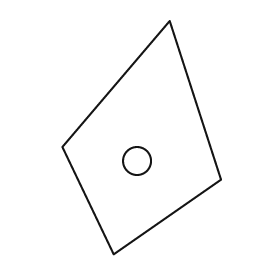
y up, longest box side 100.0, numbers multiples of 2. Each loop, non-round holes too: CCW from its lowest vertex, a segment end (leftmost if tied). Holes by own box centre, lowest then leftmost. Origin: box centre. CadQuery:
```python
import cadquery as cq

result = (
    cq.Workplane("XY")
    .moveTo(-12.0, -50.0)
    .lineTo(34.0, -18.0)
    .lineTo(12.0, 50.0)
    .lineTo(-34.0, -4.0)
    .close()
    .moveTo(-2.0, -10.0)
    .circle(6.0)
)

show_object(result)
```